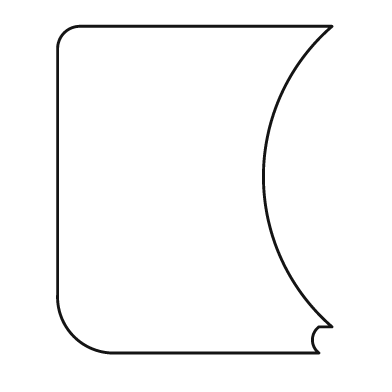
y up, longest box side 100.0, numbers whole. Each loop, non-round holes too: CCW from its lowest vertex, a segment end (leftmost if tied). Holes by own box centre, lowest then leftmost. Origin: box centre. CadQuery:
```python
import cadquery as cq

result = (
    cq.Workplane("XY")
    .moveTo(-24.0, -50.0)
    .lineTo(38.0, -50.0)
    .threePointArc((36.0, -46.0), (38.0, -42.0))
    .lineTo(42.0, -42.0)
    .threePointArc((21.0, 4.0), (42.0, 50.0))
    .lineTo(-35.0, 50.0)
    .threePointArc((-40.0, 48.0), (-42.0, 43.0))
    .lineTo(-42.0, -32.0)
    .threePointArc((-37.0, -45.0), (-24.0, -50.0))
    .close()
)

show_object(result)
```